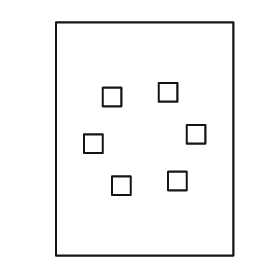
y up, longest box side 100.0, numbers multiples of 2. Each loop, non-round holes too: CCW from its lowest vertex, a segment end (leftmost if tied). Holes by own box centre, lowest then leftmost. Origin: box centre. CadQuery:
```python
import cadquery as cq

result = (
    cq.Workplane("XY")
    .moveTo(-38.0, -50.0)
    .lineTo(38.0, -50.0)
    .lineTo(38.0, 50.0)
    .lineTo(-38.0, 50.0)
    .close()
    .moveTo(-14.0, -24.0)
    .lineTo(-6.0, -24.0)
    .lineTo(-6.0, -16.0)
    .lineTo(-14.0, -16.0)
    .close()
    .moveTo(10.0, -22.0)
    .lineTo(18.0, -22.0)
    .lineTo(18.0, -14.0)
    .lineTo(10.0, -14.0)
    .close()
    .moveTo(-26.0, -6.0)
    .lineTo(-18.0, -6.0)
    .lineTo(-18.0, 2.0)
    .lineTo(-26.0, 2.0)
    .close()
    .moveTo(18.0, -2.0)
    .lineTo(26.0, -2.0)
    .lineTo(26.0, 6.0)
    .lineTo(18.0, 6.0)
    .close()
    .moveTo(-18.0, 14.0)
    .lineTo(-10.0, 14.0)
    .lineTo(-10.0, 22.0)
    .lineTo(-18.0, 22.0)
    .close()
    .moveTo(6.0, 16.0)
    .lineTo(14.0, 16.0)
    .lineTo(14.0, 24.0)
    .lineTo(6.0, 24.0)
    .close()
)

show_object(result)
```